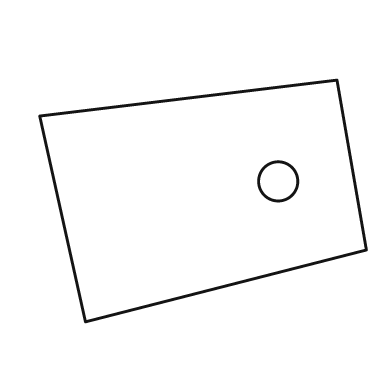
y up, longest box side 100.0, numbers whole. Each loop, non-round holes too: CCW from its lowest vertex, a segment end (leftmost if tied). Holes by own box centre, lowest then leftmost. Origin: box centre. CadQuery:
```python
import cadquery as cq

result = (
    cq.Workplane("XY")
    .moveTo(-36.0, -37.0)
    .lineTo(50.0, -15.0)
    .lineTo(41.0, 37.0)
    .lineTo(-50.0, 26.0)
    .close()
    .moveTo(23.0, 6.0)
    .circle(6.0)
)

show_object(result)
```